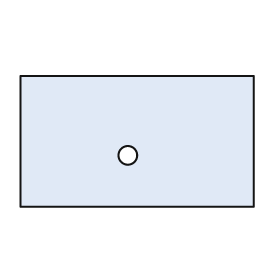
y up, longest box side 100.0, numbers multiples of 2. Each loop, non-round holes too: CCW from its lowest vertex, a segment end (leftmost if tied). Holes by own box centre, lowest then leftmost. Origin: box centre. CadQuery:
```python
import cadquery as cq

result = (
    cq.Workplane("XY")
    .moveTo(-50.0, -28.0)
    .lineTo(50.0, -28.0)
    .lineTo(50.0, 28.0)
    .lineTo(-50.0, 28.0)
    .close()
    .moveTo(-4.0, -6.0)
    .circle(4.0)
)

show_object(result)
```